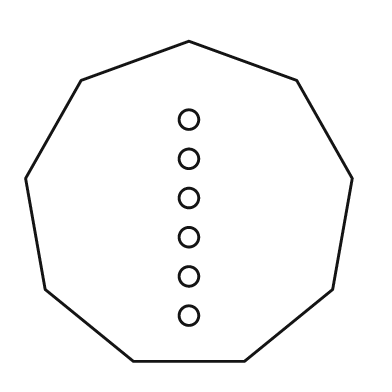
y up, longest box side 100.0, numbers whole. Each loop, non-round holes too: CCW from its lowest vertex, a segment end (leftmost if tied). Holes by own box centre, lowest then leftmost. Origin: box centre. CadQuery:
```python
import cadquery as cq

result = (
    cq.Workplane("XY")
    .moveTo(-17.0, -49.0)
    .lineTo(17.0, -49.0)
    .lineTo(44.0, -27.0)
    .lineTo(50.0, 7.0)
    .lineTo(33.0, 37.0)
    .lineTo(0.0, 49.0)
    .lineTo(-33.0, 37.0)
    .lineTo(-50.0, 7.0)
    .lineTo(-44.0, -27.0)
    .close()
    .moveTo(0.0, -35.0)
    .circle(3.0)
    .moveTo(0.0, -23.0)
    .circle(3.0)
    .moveTo(0.0, -11.0)
    .circle(3.0)
    .moveTo(0.0, 1.0)
    .circle(3.0)
    .moveTo(0.0, 13.0)
    .circle(3.0)
    .moveTo(0.0, 25.0)
    .circle(3.0)
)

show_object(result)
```